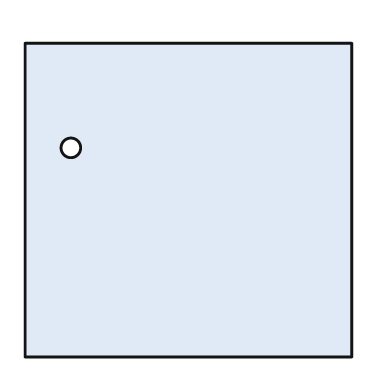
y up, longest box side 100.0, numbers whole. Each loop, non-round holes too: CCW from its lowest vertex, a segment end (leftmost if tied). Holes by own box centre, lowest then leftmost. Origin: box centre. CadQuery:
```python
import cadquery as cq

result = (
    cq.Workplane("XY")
    .moveTo(-50.0, -48.0)
    .lineTo(50.0, -48.0)
    .lineTo(50.0, 48.0)
    .lineTo(-50.0, 48.0)
    .close()
    .moveTo(-36.0, 16.0)
    .circle(3.0)
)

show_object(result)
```